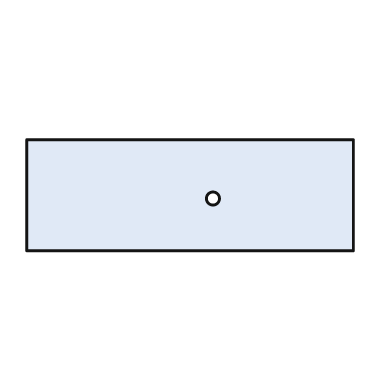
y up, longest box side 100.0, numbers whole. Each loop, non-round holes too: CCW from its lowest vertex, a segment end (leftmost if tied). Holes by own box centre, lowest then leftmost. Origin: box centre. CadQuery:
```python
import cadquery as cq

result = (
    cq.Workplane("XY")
    .moveTo(-50.0, -17.0)
    .lineTo(50.0, -17.0)
    .lineTo(50.0, 17.0)
    .lineTo(-50.0, 17.0)
    .close()
    .moveTo(7.0, -1.0)
    .circle(2.0)
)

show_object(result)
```